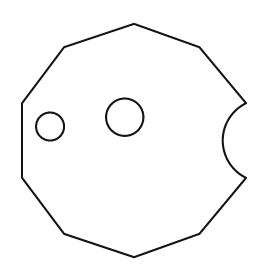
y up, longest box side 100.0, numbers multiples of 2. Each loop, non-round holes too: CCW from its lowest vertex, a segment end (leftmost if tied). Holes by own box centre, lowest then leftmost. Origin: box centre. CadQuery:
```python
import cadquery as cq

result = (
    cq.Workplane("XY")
    .moveTo(0.0, -50.0)
    .lineTo(28.0, -40.0)
    .lineTo(48.0, -16.0)
    .threePointArc((38.0, 0.0), (48.0, 16.0))
    .lineTo(28.0, 40.0)
    .lineTo(0.0, 50.0)
    .lineTo(-30.0, 40.0)
    .lineTo(-48.0, 16.0)
    .lineTo(-48.0, -16.0)
    .lineTo(-30.0, -40.0)
    .close()
    .moveTo(-36.0, 6.0)
    .circle(6.0)
    .moveTo(-4.0, 10.0)
    .circle(8.0)
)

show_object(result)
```